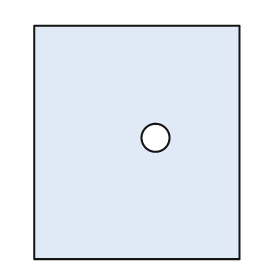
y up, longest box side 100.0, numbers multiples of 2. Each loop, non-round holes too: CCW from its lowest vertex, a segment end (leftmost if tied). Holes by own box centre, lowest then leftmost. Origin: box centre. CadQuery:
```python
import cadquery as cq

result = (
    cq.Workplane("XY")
    .moveTo(-44.0, -50.0)
    .lineTo(44.0, -50.0)
    .lineTo(44.0, 50.0)
    .lineTo(-44.0, 50.0)
    .close()
    .moveTo(8.0, 2.0)
    .circle(6.0)
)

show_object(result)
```